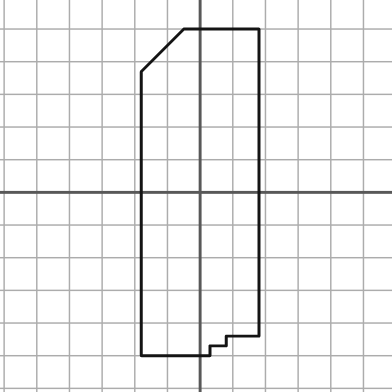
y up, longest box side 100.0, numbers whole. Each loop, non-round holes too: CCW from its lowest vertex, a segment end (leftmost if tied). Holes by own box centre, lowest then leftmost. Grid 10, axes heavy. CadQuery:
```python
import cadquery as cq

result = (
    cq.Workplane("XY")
    .moveTo(-18.0, -50.0)
    .lineTo(3.0, -50.0)
    .lineTo(3.0, -47.0)
    .lineTo(8.0, -47.0)
    .lineTo(8.0, -44.0)
    .lineTo(18.0, -44.0)
    .lineTo(18.0, 50.0)
    .lineTo(-5.0, 50.0)
    .lineTo(-18.0, 37.0)
    .close()
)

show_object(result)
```